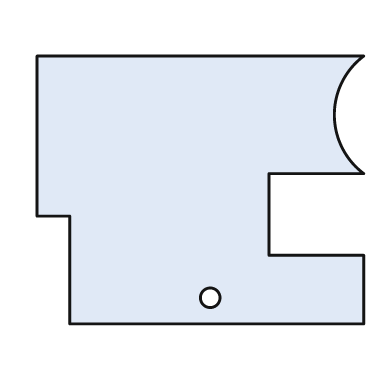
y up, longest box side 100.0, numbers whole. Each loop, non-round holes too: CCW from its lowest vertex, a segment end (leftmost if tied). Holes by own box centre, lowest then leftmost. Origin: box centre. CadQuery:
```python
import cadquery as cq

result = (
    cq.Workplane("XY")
    .moveTo(-40.0, -41.0)
    .lineTo(50.0, -41.0)
    .lineTo(50.0, -20.0)
    .lineTo(21.0, -20.0)
    .lineTo(21.0, 5.0)
    .lineTo(50.0, 5.0)
    .threePointArc((41.0, 23.0), (50.0, 41.0))
    .lineTo(-50.0, 41.0)
    .lineTo(-50.0, -8.0)
    .lineTo(-40.0, -8.0)
    .close()
    .moveTo(3.0, -33.0)
    .circle(3.0)
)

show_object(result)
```